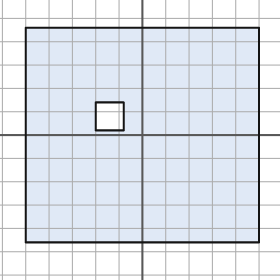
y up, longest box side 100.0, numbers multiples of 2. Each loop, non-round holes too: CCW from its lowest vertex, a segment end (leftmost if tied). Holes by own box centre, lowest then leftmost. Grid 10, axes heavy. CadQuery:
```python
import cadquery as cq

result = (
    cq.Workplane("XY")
    .moveTo(-50.0, -46.0)
    .lineTo(50.0, -46.0)
    .lineTo(50.0, 46.0)
    .lineTo(-50.0, 46.0)
    .close()
    .moveTo(-20.0, 2.0)
    .lineTo(-8.0, 2.0)
    .lineTo(-8.0, 14.0)
    .lineTo(-20.0, 14.0)
    .close()
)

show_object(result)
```